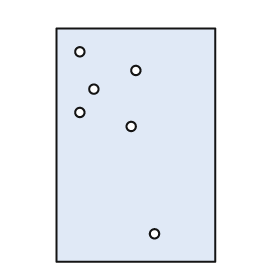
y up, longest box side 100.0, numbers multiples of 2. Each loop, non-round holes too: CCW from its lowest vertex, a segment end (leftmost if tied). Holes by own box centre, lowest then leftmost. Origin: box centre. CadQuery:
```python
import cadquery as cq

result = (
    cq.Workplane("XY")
    .moveTo(-34.0, -50.0)
    .lineTo(34.0, -50.0)
    .lineTo(34.0, 50.0)
    .lineTo(-34.0, 50.0)
    .close()
    .moveTo(8.0, -38.0)
    .circle(2.0)
    .moveTo(-2.0, 8.0)
    .circle(2.0)
    .moveTo(-24.0, 14.0)
    .circle(2.0)
    .moveTo(-18.0, 24.0)
    .circle(2.0)
    .moveTo(0.0, 32.0)
    .circle(2.0)
    .moveTo(-24.0, 40.0)
    .circle(2.0)
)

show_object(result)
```